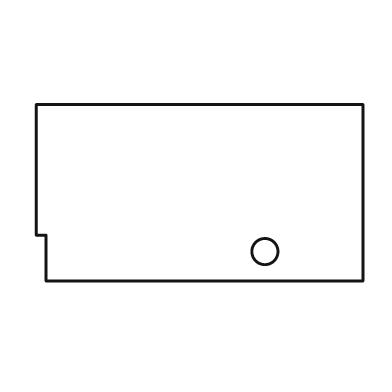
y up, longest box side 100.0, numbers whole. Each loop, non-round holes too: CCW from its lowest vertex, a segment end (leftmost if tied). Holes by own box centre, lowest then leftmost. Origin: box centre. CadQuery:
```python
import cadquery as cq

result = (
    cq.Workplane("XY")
    .moveTo(-47.0, -27.0)
    .lineTo(50.0, -27.0)
    .lineTo(50.0, 27.0)
    .lineTo(-50.0, 27.0)
    .lineTo(-50.0, -13.0)
    .lineTo(-47.0, -13.0)
    .close()
    .moveTo(20.0, -18.0)
    .circle(4.0)
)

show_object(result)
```